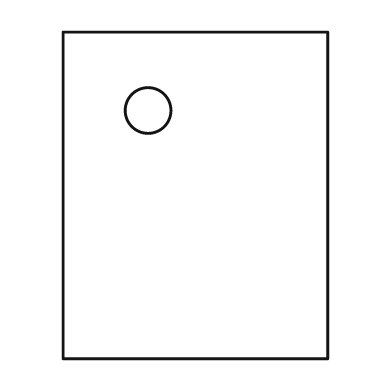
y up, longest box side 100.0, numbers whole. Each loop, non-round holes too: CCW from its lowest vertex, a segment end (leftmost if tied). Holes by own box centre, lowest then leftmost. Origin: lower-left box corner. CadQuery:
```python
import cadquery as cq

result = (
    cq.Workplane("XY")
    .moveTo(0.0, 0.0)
    .lineTo(81.0, 0.0)
    .lineTo(81.0, 100.0)
    .lineTo(0.0, 100.0)
    .close()
    .moveTo(26.0, 76.0)
    .circle(7.0)
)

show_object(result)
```